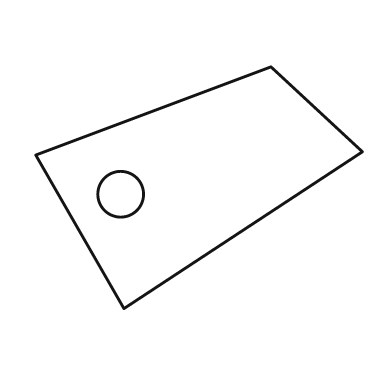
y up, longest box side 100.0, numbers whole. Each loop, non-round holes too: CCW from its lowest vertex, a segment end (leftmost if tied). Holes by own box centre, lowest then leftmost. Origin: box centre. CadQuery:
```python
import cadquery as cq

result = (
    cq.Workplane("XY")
    .moveTo(-23.0, -37.0)
    .lineTo(50.0, 11.0)
    .lineTo(22.0, 37.0)
    .lineTo(-50.0, 10.0)
    .close()
    .moveTo(-24.0, -2.0)
    .circle(7.0)
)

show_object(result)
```